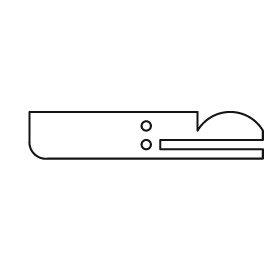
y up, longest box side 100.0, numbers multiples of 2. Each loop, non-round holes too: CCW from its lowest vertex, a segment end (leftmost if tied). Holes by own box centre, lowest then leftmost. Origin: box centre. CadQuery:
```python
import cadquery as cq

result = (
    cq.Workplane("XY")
    .moveTo(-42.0, -10.0)
    .lineTo(50.0, -10.0)
    .lineTo(50.0, -6.0)
    .lineTo(6.0, -6.0)
    .lineTo(6.0, -2.0)
    .lineTo(50.0, -2.0)
    .lineTo(50.0, 2.0)
    .threePointArc((36.0, 10.0), (22.0, 2.0))
    .lineTo(22.0, 10.0)
    .lineTo(-50.0, 10.0)
    .lineTo(-50.0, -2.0)
    .threePointArc((-48.0, -8.0), (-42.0, -10.0))
    .close()
    .moveTo(0.0, -4.0)
    .circle(2.0)
    .moveTo(0.0, 4.0)
    .circle(2.0)
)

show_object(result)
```